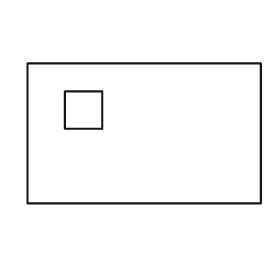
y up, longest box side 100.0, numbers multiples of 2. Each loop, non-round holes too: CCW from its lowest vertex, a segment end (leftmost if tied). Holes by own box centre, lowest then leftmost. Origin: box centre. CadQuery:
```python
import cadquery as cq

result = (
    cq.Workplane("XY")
    .moveTo(-50.0, -30.0)
    .lineTo(50.0, -30.0)
    .lineTo(50.0, 30.0)
    .lineTo(-50.0, 30.0)
    .close()
    .moveTo(-34.0, 2.0)
    .lineTo(-18.0, 2.0)
    .lineTo(-18.0, 18.0)
    .lineTo(-34.0, 18.0)
    .close()
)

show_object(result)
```